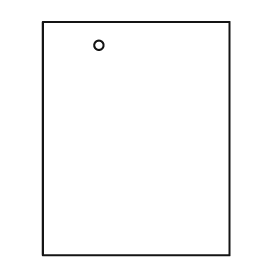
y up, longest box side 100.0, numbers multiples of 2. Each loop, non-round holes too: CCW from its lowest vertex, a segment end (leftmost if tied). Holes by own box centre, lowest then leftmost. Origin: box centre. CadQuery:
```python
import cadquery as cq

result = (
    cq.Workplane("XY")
    .moveTo(-40.0, -50.0)
    .lineTo(40.0, -50.0)
    .lineTo(40.0, 50.0)
    .lineTo(-40.0, 50.0)
    .close()
    .moveTo(-16.0, 40.0)
    .circle(2.0)
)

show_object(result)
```